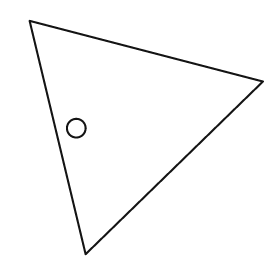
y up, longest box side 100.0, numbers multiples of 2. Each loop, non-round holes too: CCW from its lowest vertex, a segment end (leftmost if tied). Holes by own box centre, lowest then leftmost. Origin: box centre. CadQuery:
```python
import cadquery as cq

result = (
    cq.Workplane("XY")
    .moveTo(-26.0, -50.0)
    .lineTo(50.0, 24.0)
    .lineTo(-50.0, 50.0)
    .close()
    .moveTo(-30.0, 4.0)
    .circle(4.0)
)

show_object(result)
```